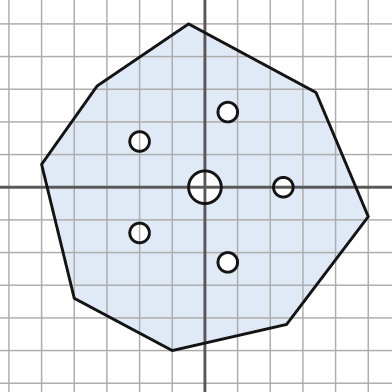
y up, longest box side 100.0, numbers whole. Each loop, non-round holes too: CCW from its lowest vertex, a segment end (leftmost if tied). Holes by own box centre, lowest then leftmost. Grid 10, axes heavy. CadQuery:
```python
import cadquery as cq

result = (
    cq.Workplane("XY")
    .moveTo(-10.0, -50.0)
    .lineTo(25.0, -42.0)
    .lineTo(50.0, -9.0)
    .lineTo(34.0, 29.0)
    .lineTo(-5.0, 50.0)
    .lineTo(-33.0, 31.0)
    .lineTo(-50.0, 7.0)
    .lineTo(-40.0, -34.0)
    .close()
    .moveTo(7.0, -23.0)
    .circle(3.0)
    .moveTo(-20.0, -14.0)
    .circle(3.0)
    .moveTo(0.0, 0.0)
    .circle(5.0)
    .moveTo(24.0, 0.0)
    .circle(3.0)
    .moveTo(-20.0, 14.0)
    .circle(3.0)
    .moveTo(7.0, 23.0)
    .circle(3.0)
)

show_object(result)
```